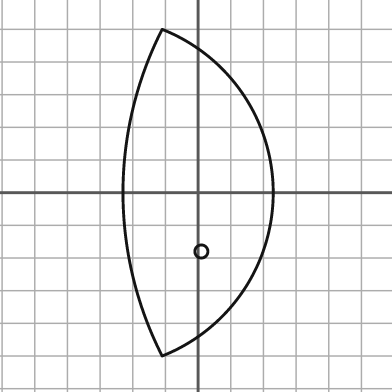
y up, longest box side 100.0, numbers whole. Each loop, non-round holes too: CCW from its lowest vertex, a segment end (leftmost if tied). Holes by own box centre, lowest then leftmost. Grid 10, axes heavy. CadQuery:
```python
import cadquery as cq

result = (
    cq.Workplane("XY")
    .moveTo(-11.0, -50.0)
    .threePointArc((23.0, 0.0), (-11.0, 50.0))
    .threePointArc((-23.0, 0.0), (-11.0, -50.0))
    .close()
    .moveTo(1.0, -18.0)
    .circle(2.0)
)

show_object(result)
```